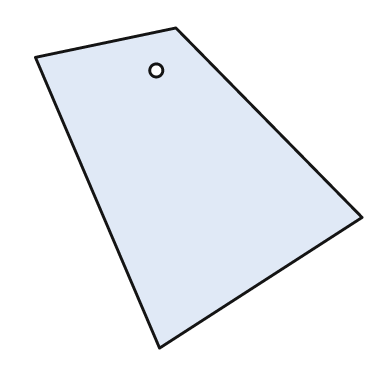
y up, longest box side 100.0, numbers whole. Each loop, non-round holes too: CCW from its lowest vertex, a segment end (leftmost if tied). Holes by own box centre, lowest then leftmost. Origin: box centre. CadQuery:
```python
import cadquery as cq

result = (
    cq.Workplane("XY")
    .moveTo(-12.0, -49.0)
    .lineTo(50.0, -9.0)
    .lineTo(-7.0, 49.0)
    .lineTo(-50.0, 40.0)
    .close()
    .moveTo(-13.0, 36.0)
    .circle(2.0)
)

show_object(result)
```